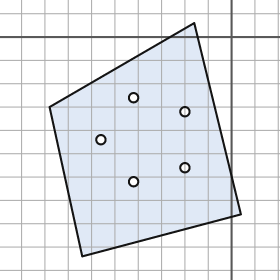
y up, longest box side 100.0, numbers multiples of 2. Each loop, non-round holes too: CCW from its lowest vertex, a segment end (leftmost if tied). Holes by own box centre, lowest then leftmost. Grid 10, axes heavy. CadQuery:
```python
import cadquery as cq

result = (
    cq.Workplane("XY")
    .moveTo(-64.0, -94.0)
    .lineTo(4.0, -76.0)
    .lineTo(-16.0, 6.0)
    .lineTo(-78.0, -30.0)
    .close()
    .moveTo(-42.0, -62.0)
    .circle(2.0)
    .moveTo(-20.0, -56.0)
    .circle(2.0)
    .moveTo(-56.0, -44.0)
    .circle(2.0)
    .moveTo(-20.0, -32.0)
    .circle(2.0)
    .moveTo(-42.0, -26.0)
    .circle(2.0)
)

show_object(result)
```